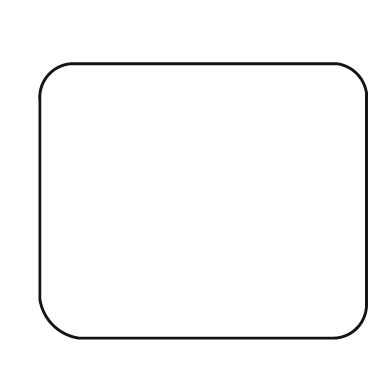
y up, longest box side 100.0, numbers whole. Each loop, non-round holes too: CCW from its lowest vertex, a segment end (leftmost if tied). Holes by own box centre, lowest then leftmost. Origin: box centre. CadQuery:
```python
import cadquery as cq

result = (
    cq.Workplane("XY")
    .moveTo(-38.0, -42.0)
    .lineTo(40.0, -42.0)
    .threePointArc((47.0, -39.0), (50.0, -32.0))
    .lineTo(50.0, 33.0)
    .threePointArc((47.0, 39.0), (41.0, 42.0))
    .lineTo(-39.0, 42.0)
    .threePointArc((-47.0, 39.0), (-50.0, 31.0))
    .lineTo(-50.0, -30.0)
    .threePointArc((-46.0, -38.0), (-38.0, -42.0))
    .close()
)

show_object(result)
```